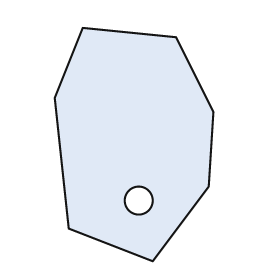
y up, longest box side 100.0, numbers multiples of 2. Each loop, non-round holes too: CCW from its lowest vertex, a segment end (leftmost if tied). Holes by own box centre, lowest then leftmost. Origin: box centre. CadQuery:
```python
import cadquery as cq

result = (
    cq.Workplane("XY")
    .moveTo(8.0, -50.0)
    .lineTo(32.0, -18.0)
    .lineTo(34.0, 14.0)
    .lineTo(18.0, 46.0)
    .lineTo(-22.0, 50.0)
    .lineTo(-34.0, 20.0)
    .lineTo(-28.0, -36.0)
    .close()
    .moveTo(2.0, -24.0)
    .circle(6.0)
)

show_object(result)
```